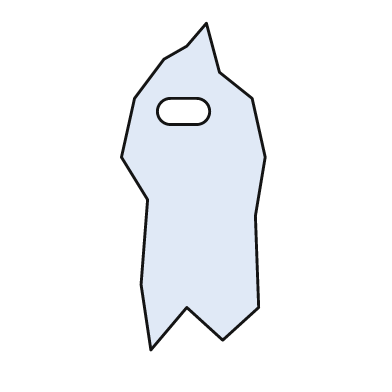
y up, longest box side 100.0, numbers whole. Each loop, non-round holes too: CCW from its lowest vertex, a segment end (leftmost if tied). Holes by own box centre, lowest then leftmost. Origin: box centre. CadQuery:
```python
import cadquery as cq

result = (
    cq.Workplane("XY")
    .moveTo(-13.0, -50.0)
    .lineTo(-2.0, -37.0)
    .lineTo(9.0, -47.0)
    .lineTo(20.0, -37.0)
    .lineTo(19.0, -9.0)
    .lineTo(22.0, 9.0)
    .lineTo(18.0, 27.0)
    .lineTo(8.0, 35.0)
    .lineTo(4.0, 50.0)
    .lineTo(-2.0, 43.0)
    .lineTo(-9.0, 39.0)
    .lineTo(-18.0, 27.0)
    .lineTo(-22.0, 9.0)
    .lineTo(-14.0, -4.0)
    .lineTo(-16.0, -30.0)
    .close()
    .moveTo(-7.0, 19.0)
    .lineTo(1.0, 19.0)
    .threePointArc((5.0, 23.0), (1.0, 27.0))
    .lineTo(-7.0, 27.0)
    .threePointArc((-11.0, 23.0), (-7.0, 19.0))
    .close()
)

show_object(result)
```